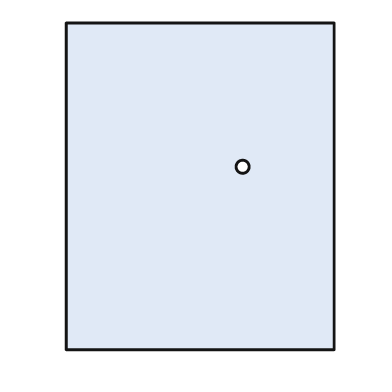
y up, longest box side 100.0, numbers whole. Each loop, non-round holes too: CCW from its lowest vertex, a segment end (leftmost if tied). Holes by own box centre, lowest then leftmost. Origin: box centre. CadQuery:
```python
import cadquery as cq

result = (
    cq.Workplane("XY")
    .moveTo(-41.0, -50.0)
    .lineTo(41.0, -50.0)
    .lineTo(41.0, 50.0)
    .lineTo(-41.0, 50.0)
    .close()
    .moveTo(13.0, 6.0)
    .circle(2.0)
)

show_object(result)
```